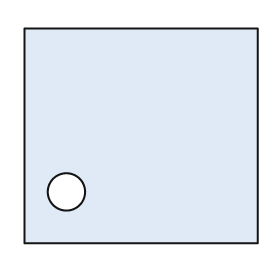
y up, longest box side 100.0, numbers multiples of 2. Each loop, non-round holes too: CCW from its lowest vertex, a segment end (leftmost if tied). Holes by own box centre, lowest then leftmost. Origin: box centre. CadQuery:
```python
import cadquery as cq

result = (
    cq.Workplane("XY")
    .moveTo(-50.0, -46.0)
    .lineTo(50.0, -46.0)
    .lineTo(50.0, 46.0)
    .lineTo(-50.0, 46.0)
    .close()
    .moveTo(-32.0, -24.0)
    .circle(8.0)
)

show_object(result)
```